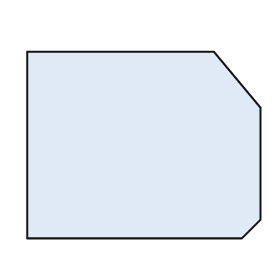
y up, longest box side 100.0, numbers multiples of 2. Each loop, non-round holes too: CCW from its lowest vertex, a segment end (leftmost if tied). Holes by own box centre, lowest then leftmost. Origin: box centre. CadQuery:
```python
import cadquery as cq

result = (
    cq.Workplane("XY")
    .moveTo(-50.0, -40.0)
    .lineTo(42.0, -40.0)
    .lineTo(50.0, -32.0)
    .lineTo(50.0, 16.0)
    .lineTo(30.0, 40.0)
    .lineTo(-50.0, 40.0)
    .close()
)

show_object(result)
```